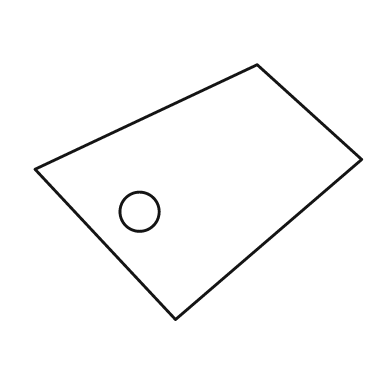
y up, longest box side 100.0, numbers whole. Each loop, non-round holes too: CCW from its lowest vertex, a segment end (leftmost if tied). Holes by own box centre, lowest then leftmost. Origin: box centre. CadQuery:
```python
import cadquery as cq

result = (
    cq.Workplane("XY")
    .moveTo(-7.0, -39.0)
    .lineTo(50.0, 10.0)
    .lineTo(18.0, 39.0)
    .lineTo(-50.0, 7.0)
    .close()
    .moveTo(-18.0, -6.0)
    .circle(6.0)
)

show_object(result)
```